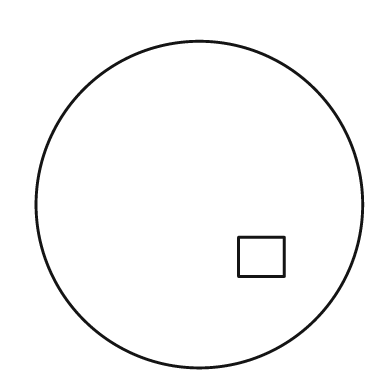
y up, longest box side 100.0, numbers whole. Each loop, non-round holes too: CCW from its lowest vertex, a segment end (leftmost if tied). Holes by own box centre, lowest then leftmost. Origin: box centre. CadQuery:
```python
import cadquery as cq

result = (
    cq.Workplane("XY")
    .moveTo(0.0, 0.0)
    .circle(50.0)
    .moveTo(12.0, -22.0)
    .lineTo(26.0, -22.0)
    .lineTo(26.0, -10.0)
    .lineTo(12.0, -10.0)
    .close()
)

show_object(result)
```